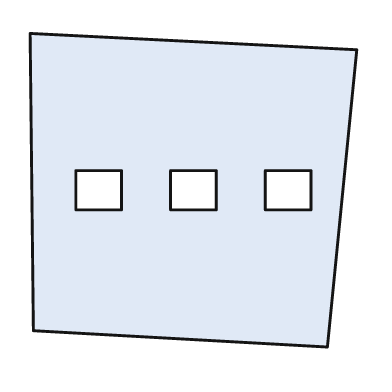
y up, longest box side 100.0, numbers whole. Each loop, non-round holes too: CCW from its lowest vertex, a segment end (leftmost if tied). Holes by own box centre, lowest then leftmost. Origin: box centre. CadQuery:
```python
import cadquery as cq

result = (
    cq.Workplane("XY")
    .moveTo(41.0, -48.0)
    .lineTo(50.0, 43.0)
    .lineTo(-50.0, 48.0)
    .lineTo(-49.0, -43.0)
    .close()
    .moveTo(-36.0, -6.0)
    .lineTo(-22.0, -6.0)
    .lineTo(-22.0, 6.0)
    .lineTo(-36.0, 6.0)
    .close()
    .moveTo(-7.0, -6.0)
    .lineTo(7.0, -6.0)
    .lineTo(7.0, 6.0)
    .lineTo(-7.0, 6.0)
    .close()
    .moveTo(22.0, -6.0)
    .lineTo(36.0, -6.0)
    .lineTo(36.0, 6.0)
    .lineTo(22.0, 6.0)
    .close()
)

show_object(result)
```